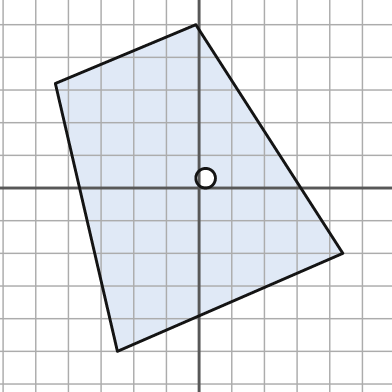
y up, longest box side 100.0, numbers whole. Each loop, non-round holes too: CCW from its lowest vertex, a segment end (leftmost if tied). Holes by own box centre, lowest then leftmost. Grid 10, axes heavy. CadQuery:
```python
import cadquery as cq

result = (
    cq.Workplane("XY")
    .moveTo(-25.0, -50.0)
    .lineTo(44.0, -20.0)
    .lineTo(-1.0, 50.0)
    .lineTo(-44.0, 32.0)
    .close()
    .moveTo(2.0, 3.0)
    .circle(3.0)
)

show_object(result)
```